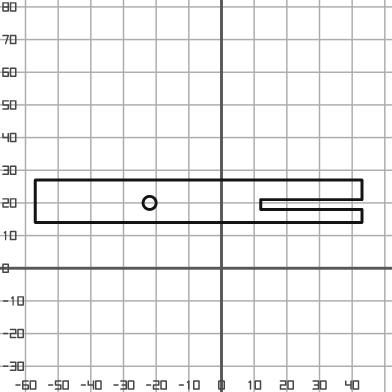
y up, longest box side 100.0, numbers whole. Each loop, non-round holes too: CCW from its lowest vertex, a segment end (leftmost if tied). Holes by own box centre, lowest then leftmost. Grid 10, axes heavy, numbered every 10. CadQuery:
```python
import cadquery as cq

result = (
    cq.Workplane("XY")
    .moveTo(-57.0, 14.0)
    .lineTo(43.0, 14.0)
    .lineTo(43.0, 18.0)
    .lineTo(12.0, 18.0)
    .lineTo(12.0, 21.0)
    .lineTo(43.0, 21.0)
    .lineTo(43.0, 27.0)
    .lineTo(-57.0, 27.0)
    .close()
    .moveTo(-22.0, 20.0)
    .circle(2.0)
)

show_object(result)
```